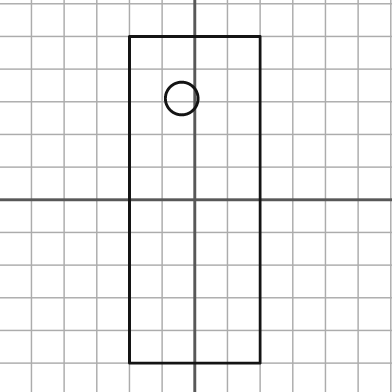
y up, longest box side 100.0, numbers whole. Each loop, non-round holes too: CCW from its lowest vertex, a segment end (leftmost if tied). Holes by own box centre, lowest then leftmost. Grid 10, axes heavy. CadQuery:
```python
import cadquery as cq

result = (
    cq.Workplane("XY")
    .moveTo(-20.0, -50.0)
    .lineTo(20.0, -50.0)
    .lineTo(20.0, 50.0)
    .lineTo(-20.0, 50.0)
    .close()
    .moveTo(-4.0, 31.0)
    .circle(5.0)
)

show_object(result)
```